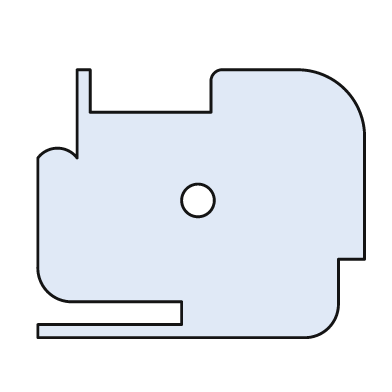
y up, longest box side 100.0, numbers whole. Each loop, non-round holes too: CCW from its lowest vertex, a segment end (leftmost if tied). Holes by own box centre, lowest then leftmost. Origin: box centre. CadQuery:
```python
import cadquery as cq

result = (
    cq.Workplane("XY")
    .moveTo(-50.0, -41.0)
    .lineTo(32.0, -41.0)
    .threePointArc((39.0, -38.0), (42.0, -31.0))
    .lineTo(42.0, -17.0)
    .lineTo(50.0, -17.0)
    .lineTo(50.0, 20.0)
    .threePointArc((44.0, 35.0), (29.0, 41.0))
    .lineTo(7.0, 41.0)
    .threePointArc((4.0, 40.0), (3.0, 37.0))
    .lineTo(3.0, 28.0)
    .lineTo(-34.0, 28.0)
    .lineTo(-34.0, 41.0)
    .lineTo(-38.0, 41.0)
    .lineTo(-38.0, 14.0)
    .threePointArc((-44.0, 17.0), (-50.0, 14.0))
    .lineTo(-50.0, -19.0)
    .threePointArc((-47.0, -27.0), (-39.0, -30.0))
    .lineTo(-6.0, -30.0)
    .lineTo(-6.0, -37.0)
    .lineTo(-50.0, -37.0)
    .close()
    .moveTo(-1.0, 1.0)
    .circle(5.0)
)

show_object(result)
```